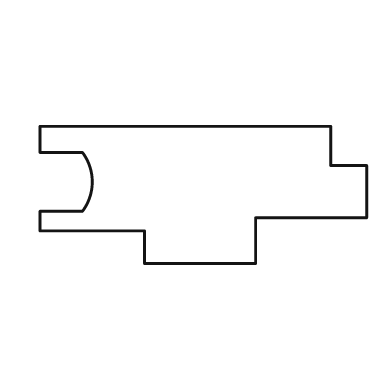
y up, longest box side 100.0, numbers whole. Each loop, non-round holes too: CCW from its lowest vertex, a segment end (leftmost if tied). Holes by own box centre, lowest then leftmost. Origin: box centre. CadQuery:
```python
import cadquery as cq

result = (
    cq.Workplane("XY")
    .moveTo(-18.0, -21.0)
    .lineTo(16.0, -21.0)
    .lineTo(16.0, -7.0)
    .lineTo(50.0, -7.0)
    .lineTo(50.0, 9.0)
    .lineTo(39.0, 9.0)
    .lineTo(39.0, 21.0)
    .lineTo(-50.0, 21.0)
    .lineTo(-50.0, 13.0)
    .lineTo(-37.0, 13.0)
    .threePointArc((-34.0, 4.0), (-37.0, -5.0))
    .lineTo(-50.0, -5.0)
    .lineTo(-50.0, -11.0)
    .lineTo(-18.0, -11.0)
    .close()
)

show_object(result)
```